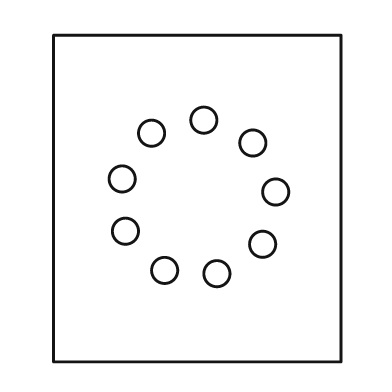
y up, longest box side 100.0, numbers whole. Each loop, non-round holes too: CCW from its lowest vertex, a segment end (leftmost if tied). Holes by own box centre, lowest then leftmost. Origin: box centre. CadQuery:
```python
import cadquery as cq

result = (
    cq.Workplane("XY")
    .moveTo(-44.0, -50.0)
    .lineTo(44.0, -50.0)
    .lineTo(44.0, 50.0)
    .lineTo(-44.0, 50.0)
    .close()
    .moveTo(6.0, -23.0)
    .circle(4.0)
    .moveTo(-10.0, -22.0)
    .circle(4.0)
    .moveTo(20.0, -14.0)
    .circle(4.0)
    .moveTo(-22.0, -10.0)
    .circle(4.0)
    .moveTo(24.0, 2.0)
    .circle(4.0)
    .moveTo(-23.0, 6.0)
    .circle(4.0)
    .moveTo(17.0, 17.0)
    .circle(4.0)
    .moveTo(-14.0, 20.0)
    .circle(4.0)
    .moveTo(2.0, 24.0)
    .circle(4.0)
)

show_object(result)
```